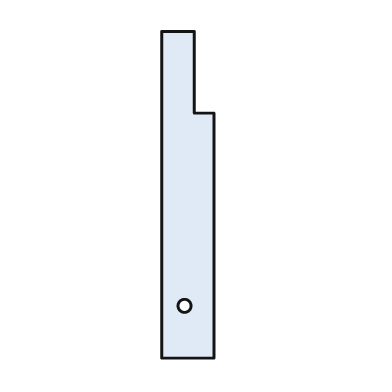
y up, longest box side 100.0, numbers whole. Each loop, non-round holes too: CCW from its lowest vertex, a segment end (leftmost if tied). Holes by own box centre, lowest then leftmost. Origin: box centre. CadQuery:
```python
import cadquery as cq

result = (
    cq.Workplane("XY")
    .moveTo(-8.0, -50.0)
    .lineTo(8.0, -50.0)
    .lineTo(8.0, 25.0)
    .lineTo(2.0, 25.0)
    .lineTo(2.0, 50.0)
    .lineTo(-8.0, 50.0)
    .close()
    .moveTo(-1.0, -34.0)
    .circle(2.0)
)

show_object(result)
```